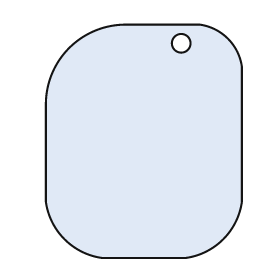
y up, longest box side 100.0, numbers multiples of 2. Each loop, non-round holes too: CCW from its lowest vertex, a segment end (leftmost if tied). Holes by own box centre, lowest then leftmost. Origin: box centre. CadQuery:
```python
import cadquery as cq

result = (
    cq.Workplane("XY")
    .moveTo(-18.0, -50.0)
    .lineTo(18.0, -50.0)
    .threePointArc((34.0, -42.0), (42.0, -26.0))
    .lineTo(42.0, 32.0)
    .threePointArc((36.0, 44.0), (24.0, 50.0))
    .lineTo(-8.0, 50.0)
    .threePointArc((-32.0, 40.0), (-42.0, 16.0))
    .lineTo(-42.0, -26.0)
    .threePointArc((-34.0, -42.0), (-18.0, -50.0))
    .close()
    .moveTo(16.0, 42.0)
    .circle(4.0)
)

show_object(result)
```